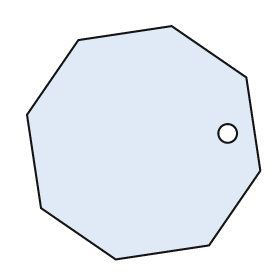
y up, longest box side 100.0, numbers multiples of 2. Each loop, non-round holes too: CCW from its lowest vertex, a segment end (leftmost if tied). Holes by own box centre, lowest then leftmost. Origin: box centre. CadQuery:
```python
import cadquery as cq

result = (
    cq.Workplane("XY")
    .moveTo(-12.0, -50.0)
    .lineTo(28.0, -44.0)
    .lineTo(50.0, -12.0)
    .lineTo(44.0, 28.0)
    .lineTo(12.0, 50.0)
    .lineTo(-28.0, 44.0)
    .lineTo(-50.0, 12.0)
    .lineTo(-44.0, -28.0)
    .close()
    .moveTo(36.0, 4.0)
    .circle(4.0)
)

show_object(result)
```